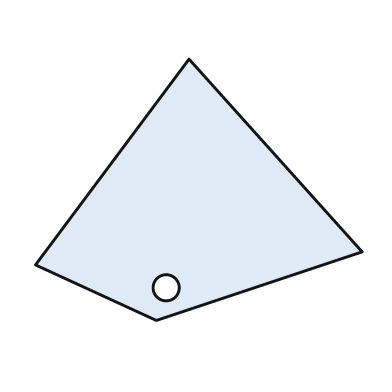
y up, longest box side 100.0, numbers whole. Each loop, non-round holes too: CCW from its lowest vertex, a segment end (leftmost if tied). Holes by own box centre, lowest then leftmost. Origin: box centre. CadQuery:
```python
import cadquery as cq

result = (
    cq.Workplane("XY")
    .moveTo(-13.0, -40.0)
    .lineTo(50.0, -19.0)
    .lineTo(-3.0, 40.0)
    .lineTo(-50.0, -23.0)
    .close()
    .moveTo(-10.0, -30.0)
    .circle(4.0)
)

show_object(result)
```